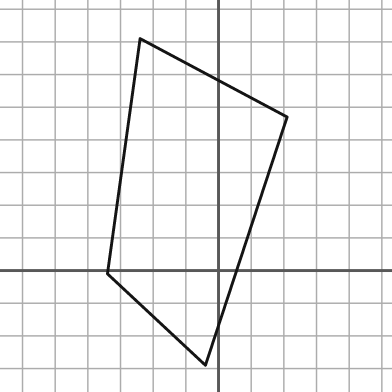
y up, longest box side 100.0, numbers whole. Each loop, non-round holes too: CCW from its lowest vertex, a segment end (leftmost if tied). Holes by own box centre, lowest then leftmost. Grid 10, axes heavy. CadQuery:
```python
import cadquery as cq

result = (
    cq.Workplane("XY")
    .moveTo(-4.0, -29.0)
    .lineTo(21.0, 47.0)
    .lineTo(-24.0, 71.0)
    .lineTo(-34.0, -1.0)
    .close()
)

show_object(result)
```